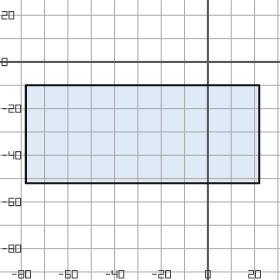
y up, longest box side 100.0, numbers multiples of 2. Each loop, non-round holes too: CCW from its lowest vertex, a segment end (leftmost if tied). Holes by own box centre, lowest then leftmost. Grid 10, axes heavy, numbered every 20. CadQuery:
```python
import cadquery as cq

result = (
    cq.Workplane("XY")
    .moveTo(-78.0, -52.0)
    .lineTo(22.0, -52.0)
    .lineTo(22.0, -10.0)
    .lineTo(-78.0, -10.0)
    .close()
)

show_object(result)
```